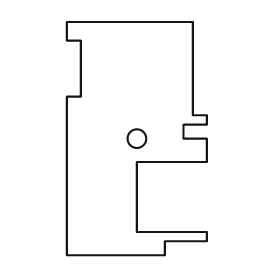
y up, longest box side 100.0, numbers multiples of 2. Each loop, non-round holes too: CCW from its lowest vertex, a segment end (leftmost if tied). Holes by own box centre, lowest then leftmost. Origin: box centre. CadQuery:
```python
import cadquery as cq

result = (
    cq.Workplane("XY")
    .moveTo(-30.0, -50.0)
    .lineTo(12.0, -50.0)
    .lineTo(12.0, -44.0)
    .lineTo(30.0, -44.0)
    .lineTo(30.0, -40.0)
    .lineTo(0.0, -40.0)
    .lineTo(0.0, -10.0)
    .lineTo(30.0, -10.0)
    .lineTo(30.0, 0.0)
    .lineTo(20.0, 0.0)
    .lineTo(20.0, 6.0)
    .lineTo(30.0, 6.0)
    .lineTo(30.0, 10.0)
    .lineTo(24.0, 10.0)
    .lineTo(24.0, 50.0)
    .lineTo(-30.0, 50.0)
    .lineTo(-30.0, 42.0)
    .lineTo(-24.0, 42.0)
    .lineTo(-24.0, 18.0)
    .lineTo(-30.0, 18.0)
    .close()
    .moveTo(0.0, 0.0)
    .circle(4.0)
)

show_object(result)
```